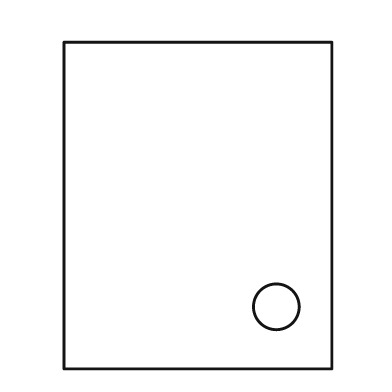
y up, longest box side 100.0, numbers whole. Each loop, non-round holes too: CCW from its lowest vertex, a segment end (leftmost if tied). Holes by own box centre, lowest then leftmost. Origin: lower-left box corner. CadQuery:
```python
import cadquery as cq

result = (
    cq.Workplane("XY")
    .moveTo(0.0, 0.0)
    .lineTo(82.0, 0.0)
    .lineTo(82.0, 100.0)
    .lineTo(0.0, 100.0)
    .close()
    .moveTo(65.0, 19.0)
    .circle(7.0)
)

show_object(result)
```